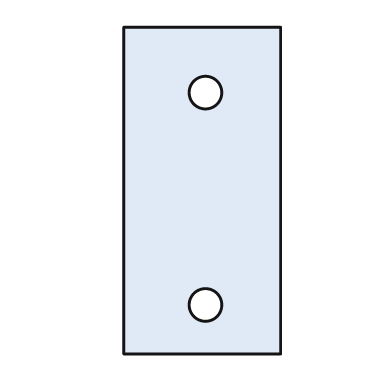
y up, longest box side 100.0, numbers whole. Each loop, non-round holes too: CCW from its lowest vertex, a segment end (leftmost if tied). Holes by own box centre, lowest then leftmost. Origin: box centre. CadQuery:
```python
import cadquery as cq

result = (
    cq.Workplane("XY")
    .moveTo(-24.0, -50.0)
    .lineTo(24.0, -50.0)
    .lineTo(24.0, 50.0)
    .lineTo(-24.0, 50.0)
    .close()
    .moveTo(1.0, -35.0)
    .circle(5.0)
    .moveTo(1.0, 30.0)
    .circle(5.0)
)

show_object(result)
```